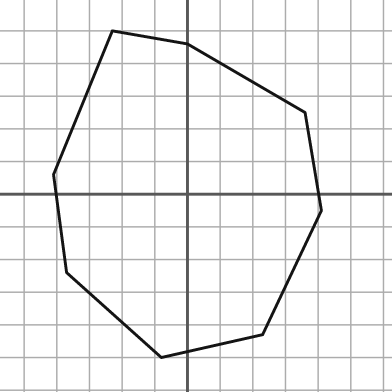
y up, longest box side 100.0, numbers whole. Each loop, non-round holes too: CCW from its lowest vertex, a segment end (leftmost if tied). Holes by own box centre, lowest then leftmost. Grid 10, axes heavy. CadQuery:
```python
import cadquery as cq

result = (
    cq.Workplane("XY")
    .moveTo(-8.0, -50.0)
    .lineTo(23.0, -43.0)
    .lineTo(41.0, -5.0)
    .lineTo(36.0, 25.0)
    .lineTo(0.0, 46.0)
    .lineTo(-23.0, 50.0)
    .lineTo(-41.0, 6.0)
    .lineTo(-37.0, -24.0)
    .close()
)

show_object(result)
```